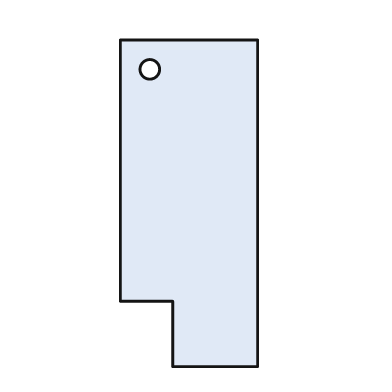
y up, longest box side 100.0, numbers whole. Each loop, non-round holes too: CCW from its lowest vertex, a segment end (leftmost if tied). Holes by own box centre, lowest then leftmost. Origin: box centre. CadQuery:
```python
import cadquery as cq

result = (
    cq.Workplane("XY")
    .moveTo(-5.0, -50.0)
    .lineTo(21.0, -50.0)
    .lineTo(21.0, 50.0)
    .lineTo(-21.0, 50.0)
    .lineTo(-21.0, -30.0)
    .lineTo(-5.0, -30.0)
    .close()
    .moveTo(-12.0, 41.0)
    .circle(3.0)
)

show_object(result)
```